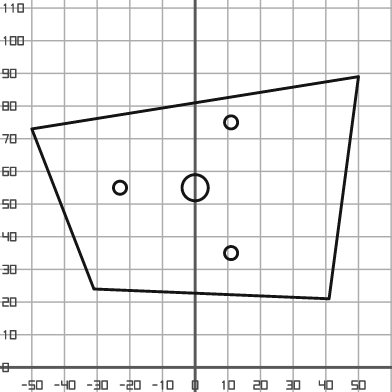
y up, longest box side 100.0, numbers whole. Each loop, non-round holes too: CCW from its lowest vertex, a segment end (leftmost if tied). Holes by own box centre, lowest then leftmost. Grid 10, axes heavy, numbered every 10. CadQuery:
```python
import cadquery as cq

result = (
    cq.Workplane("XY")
    .moveTo(41.0, 21.0)
    .lineTo(50.0, 89.0)
    .lineTo(-50.0, 73.0)
    .lineTo(-31.0, 24.0)
    .close()
    .moveTo(11.0, 35.0)
    .circle(2.0)
    .moveTo(-23.0, 55.0)
    .circle(2.0)
    .moveTo(0.0, 55.0)
    .circle(4.0)
    .moveTo(11.0, 75.0)
    .circle(2.0)
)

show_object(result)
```